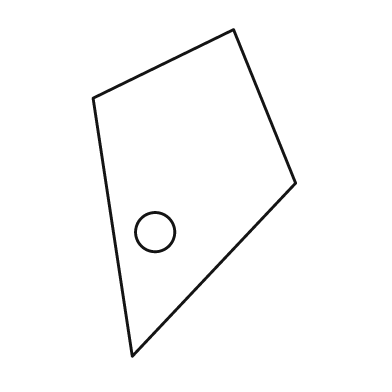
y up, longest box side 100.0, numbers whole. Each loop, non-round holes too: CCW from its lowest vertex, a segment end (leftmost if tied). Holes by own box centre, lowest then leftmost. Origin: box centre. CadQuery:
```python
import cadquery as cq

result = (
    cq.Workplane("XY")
    .moveTo(-19.0, -50.0)
    .lineTo(31.0, 3.0)
    .lineTo(12.0, 50.0)
    .lineTo(-31.0, 29.0)
    .close()
    .moveTo(-12.0, -12.0)
    .circle(6.0)
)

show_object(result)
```